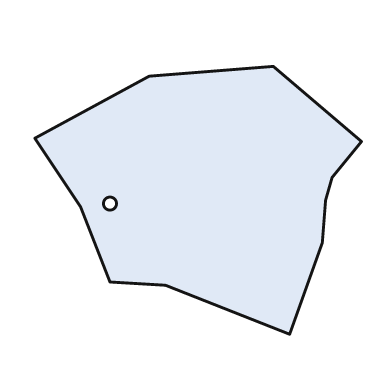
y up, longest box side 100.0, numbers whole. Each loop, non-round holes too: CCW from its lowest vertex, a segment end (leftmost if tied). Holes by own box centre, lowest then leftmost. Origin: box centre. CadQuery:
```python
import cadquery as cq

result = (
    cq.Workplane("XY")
    .moveTo(28.0, -41.0)
    .lineTo(38.0, -13.0)
    .lineTo(39.0, 0.0)
    .lineTo(41.0, 7.0)
    .lineTo(50.0, 18.0)
    .lineTo(23.0, 41.0)
    .lineTo(-15.0, 38.0)
    .lineTo(-50.0, 19.0)
    .lineTo(-36.0, -2.0)
    .lineTo(-27.0, -25.0)
    .lineTo(-10.0, -26.0)
    .close()
    .moveTo(-27.0, -1.0)
    .circle(2.0)
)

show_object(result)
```